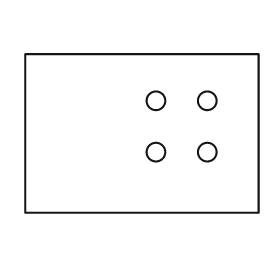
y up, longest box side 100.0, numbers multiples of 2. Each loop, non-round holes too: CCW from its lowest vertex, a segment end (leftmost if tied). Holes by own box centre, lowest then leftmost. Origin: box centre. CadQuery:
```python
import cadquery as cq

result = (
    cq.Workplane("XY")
    .moveTo(-50.0, -34.0)
    .lineTo(50.0, -34.0)
    .lineTo(50.0, 34.0)
    .lineTo(-50.0, 34.0)
    .close()
    .moveTo(6.0, -8.0)
    .circle(4.0)
    .moveTo(28.0, -8.0)
    .circle(4.0)
    .moveTo(6.0, 14.0)
    .circle(4.0)
    .moveTo(28.0, 14.0)
    .circle(4.0)
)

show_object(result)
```